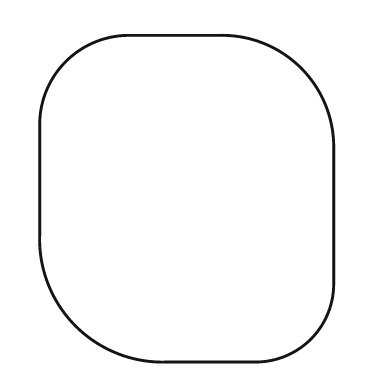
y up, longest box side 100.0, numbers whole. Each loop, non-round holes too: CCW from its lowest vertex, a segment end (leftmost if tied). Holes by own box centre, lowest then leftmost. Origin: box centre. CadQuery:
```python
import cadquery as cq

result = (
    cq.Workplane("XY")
    .moveTo(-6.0, -50.0)
    .lineTo(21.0, -50.0)
    .threePointArc((38.0, -43.0), (45.0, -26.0))
    .lineTo(45.0, 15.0)
    .threePointArc((35.0, 40.0), (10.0, 50.0))
    .lineTo(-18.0, 50.0)
    .threePointArc((-37.0, 42.0), (-45.0, 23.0))
    .lineTo(-45.0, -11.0)
    .threePointArc((-34.0, -39.0), (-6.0, -50.0))
    .close()
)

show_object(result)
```